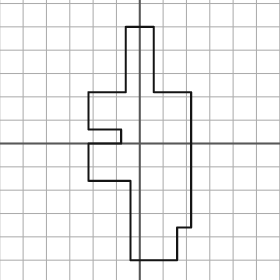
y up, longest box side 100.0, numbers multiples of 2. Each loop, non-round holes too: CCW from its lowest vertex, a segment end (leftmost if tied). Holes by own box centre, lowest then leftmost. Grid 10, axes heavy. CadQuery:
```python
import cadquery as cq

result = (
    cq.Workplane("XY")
    .moveTo(-4.0, -50.0)
    .lineTo(16.0, -50.0)
    .lineTo(16.0, -36.0)
    .lineTo(22.0, -36.0)
    .lineTo(22.0, 22.0)
    .lineTo(6.0, 22.0)
    .lineTo(6.0, 50.0)
    .lineTo(-6.0, 50.0)
    .lineTo(-6.0, 22.0)
    .lineTo(-22.0, 22.0)
    .lineTo(-22.0, 6.0)
    .lineTo(-8.0, 6.0)
    .lineTo(-8.0, 0.0)
    .lineTo(-22.0, 0.0)
    .lineTo(-22.0, -16.0)
    .lineTo(-4.0, -16.0)
    .close()
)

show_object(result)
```